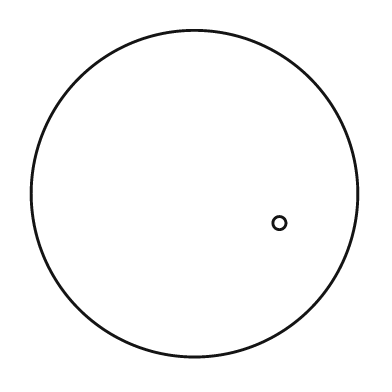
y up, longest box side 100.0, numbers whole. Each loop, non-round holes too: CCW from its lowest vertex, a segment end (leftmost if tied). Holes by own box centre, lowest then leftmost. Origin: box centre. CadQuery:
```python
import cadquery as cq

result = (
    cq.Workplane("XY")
    .moveTo(0.0, 0.0)
    .circle(50.0)
    .moveTo(26.0, -9.0)
    .circle(2.0)
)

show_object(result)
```